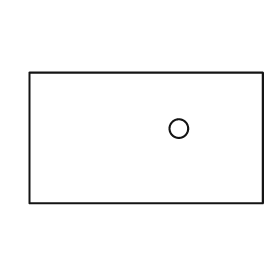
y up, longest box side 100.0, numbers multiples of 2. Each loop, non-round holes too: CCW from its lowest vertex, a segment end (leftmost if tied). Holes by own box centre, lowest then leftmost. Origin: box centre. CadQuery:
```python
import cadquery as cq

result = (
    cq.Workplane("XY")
    .moveTo(-50.0, -28.0)
    .lineTo(50.0, -28.0)
    .lineTo(50.0, 28.0)
    .lineTo(-50.0, 28.0)
    .close()
    .moveTo(14.0, 4.0)
    .circle(4.0)
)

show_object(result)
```